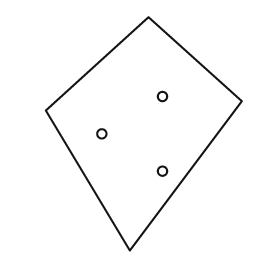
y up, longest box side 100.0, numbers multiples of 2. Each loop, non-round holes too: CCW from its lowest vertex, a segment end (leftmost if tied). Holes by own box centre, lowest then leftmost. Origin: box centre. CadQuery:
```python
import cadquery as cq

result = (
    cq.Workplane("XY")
    .moveTo(-6.0, -50.0)
    .lineTo(42.0, 14.0)
    .lineTo(2.0, 50.0)
    .lineTo(-42.0, 10.0)
    .close()
    .moveTo(8.0, -16.0)
    .circle(2.0)
    .moveTo(-18.0, 0.0)
    .circle(2.0)
    .moveTo(8.0, 16.0)
    .circle(2.0)
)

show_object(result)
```